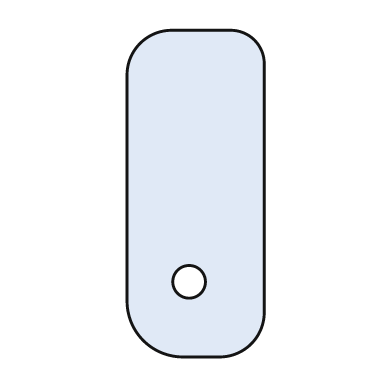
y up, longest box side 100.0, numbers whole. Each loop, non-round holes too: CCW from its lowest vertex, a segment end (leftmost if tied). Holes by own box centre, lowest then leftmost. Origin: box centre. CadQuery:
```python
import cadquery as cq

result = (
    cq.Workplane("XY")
    .moveTo(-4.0, -50.0)
    .lineTo(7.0, -50.0)
    .threePointArc((17.0, -46.0), (21.0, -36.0))
    .lineTo(21.0, 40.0)
    .threePointArc((18.0, 47.0), (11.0, 50.0))
    .lineTo(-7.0, 50.0)
    .threePointArc((-17.0, 46.0), (-21.0, 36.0))
    .lineTo(-21.0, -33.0)
    .threePointArc((-16.0, -45.0), (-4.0, -50.0))
    .close()
    .moveTo(-2.0, -27.0)
    .circle(5.0)
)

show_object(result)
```